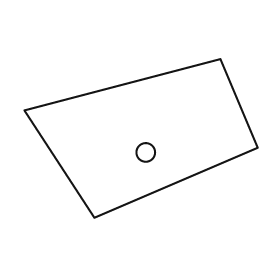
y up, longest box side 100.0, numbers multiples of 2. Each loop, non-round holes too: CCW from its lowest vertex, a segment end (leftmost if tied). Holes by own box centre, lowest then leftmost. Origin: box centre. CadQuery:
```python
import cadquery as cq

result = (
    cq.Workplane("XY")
    .moveTo(-20.0, -34.0)
    .lineTo(50.0, -4.0)
    .lineTo(34.0, 34.0)
    .lineTo(-50.0, 12.0)
    .close()
    .moveTo(2.0, -6.0)
    .circle(4.0)
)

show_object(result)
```